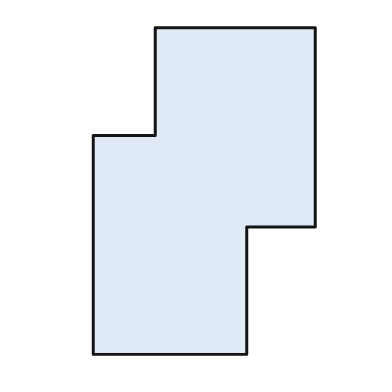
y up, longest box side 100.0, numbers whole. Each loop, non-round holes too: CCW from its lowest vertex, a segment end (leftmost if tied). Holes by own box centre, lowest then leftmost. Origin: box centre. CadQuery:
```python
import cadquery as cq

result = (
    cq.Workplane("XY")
    .moveTo(-34.0, -50.0)
    .lineTo(13.0, -50.0)
    .lineTo(13.0, -11.0)
    .lineTo(34.0, -11.0)
    .lineTo(34.0, 50.0)
    .lineTo(-15.0, 50.0)
    .lineTo(-15.0, 17.0)
    .lineTo(-34.0, 17.0)
    .close()
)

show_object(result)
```